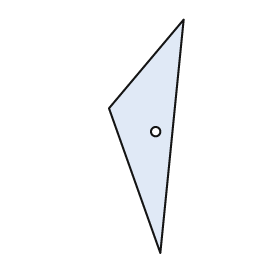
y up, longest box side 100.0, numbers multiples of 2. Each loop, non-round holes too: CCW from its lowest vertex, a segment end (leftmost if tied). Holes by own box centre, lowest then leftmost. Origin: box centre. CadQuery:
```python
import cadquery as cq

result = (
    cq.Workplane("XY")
    .moveTo(6.0, -50.0)
    .lineTo(16.0, 50.0)
    .lineTo(-16.0, 12.0)
    .close()
    .moveTo(4.0, 2.0)
    .circle(2.0)
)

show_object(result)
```